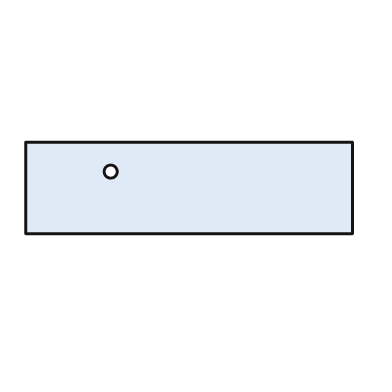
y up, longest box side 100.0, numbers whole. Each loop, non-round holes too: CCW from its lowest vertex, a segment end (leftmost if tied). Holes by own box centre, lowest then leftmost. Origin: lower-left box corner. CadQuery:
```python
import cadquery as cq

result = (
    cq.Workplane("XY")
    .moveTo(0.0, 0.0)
    .lineTo(100.0, 0.0)
    .lineTo(100.0, 28.0)
    .lineTo(0.0, 28.0)
    .close()
    .moveTo(26.0, 19.0)
    .circle(2.0)
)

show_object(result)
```